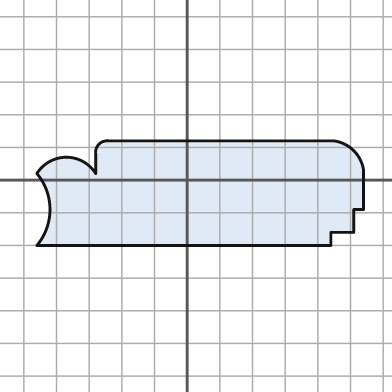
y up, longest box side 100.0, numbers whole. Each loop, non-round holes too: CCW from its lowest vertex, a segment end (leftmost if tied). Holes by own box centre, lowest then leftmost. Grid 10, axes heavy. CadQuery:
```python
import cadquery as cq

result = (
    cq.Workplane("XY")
    .moveTo(-46.0, -20.0)
    .lineTo(44.0, -20.0)
    .lineTo(44.0, -16.0)
    .lineTo(51.0, -16.0)
    .lineTo(51.0, -9.0)
    .lineTo(54.0, -9.0)
    .lineTo(54.0, 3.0)
    .threePointArc((51.0, 9.0), (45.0, 12.0))
    .lineTo(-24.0, 12.0)
    .threePointArc((-27.0, 11.0), (-28.0, 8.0))
    .lineTo(-28.0, 2.0)
    .threePointArc((-37.0, 7.0), (-46.0, 2.0))
    .threePointArc((-42.0, -9.0), (-46.0, -20.0))
    .close()
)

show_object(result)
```